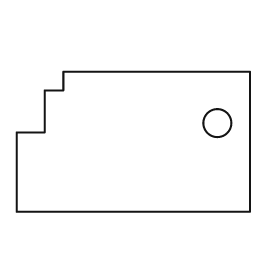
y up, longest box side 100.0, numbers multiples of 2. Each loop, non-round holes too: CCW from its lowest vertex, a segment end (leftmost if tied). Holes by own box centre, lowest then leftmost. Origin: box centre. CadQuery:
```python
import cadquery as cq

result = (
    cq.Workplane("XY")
    .moveTo(-50.0, -30.0)
    .lineTo(50.0, -30.0)
    .lineTo(50.0, 30.0)
    .lineTo(-30.0, 30.0)
    .lineTo(-30.0, 22.0)
    .lineTo(-38.0, 22.0)
    .lineTo(-38.0, 4.0)
    .lineTo(-50.0, 4.0)
    .close()
    .moveTo(36.0, 8.0)
    .circle(6.0)
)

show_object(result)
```